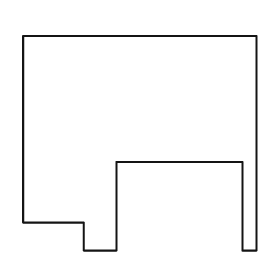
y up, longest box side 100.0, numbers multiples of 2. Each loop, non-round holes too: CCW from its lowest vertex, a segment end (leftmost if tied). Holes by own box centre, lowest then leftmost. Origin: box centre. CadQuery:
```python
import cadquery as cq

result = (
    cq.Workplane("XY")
    .moveTo(-24.0, -46.0)
    .lineTo(-10.0, -46.0)
    .lineTo(-10.0, -8.0)
    .lineTo(44.0, -8.0)
    .lineTo(44.0, -46.0)
    .lineTo(50.0, -46.0)
    .lineTo(50.0, 46.0)
    .lineTo(-50.0, 46.0)
    .lineTo(-50.0, -34.0)
    .lineTo(-24.0, -34.0)
    .close()
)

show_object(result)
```